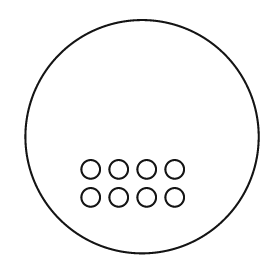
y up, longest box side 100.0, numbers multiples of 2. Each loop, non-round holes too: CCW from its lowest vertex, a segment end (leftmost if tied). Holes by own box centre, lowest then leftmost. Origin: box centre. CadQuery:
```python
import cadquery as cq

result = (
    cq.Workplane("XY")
    .moveTo(0.0, 0.0)
    .circle(50.0)
    .moveTo(-22.0, -26.0)
    .circle(4.0)
    .moveTo(-10.0, -26.0)
    .circle(4.0)
    .moveTo(2.0, -26.0)
    .circle(4.0)
    .moveTo(14.0, -26.0)
    .circle(4.0)
    .moveTo(-22.0, -14.0)
    .circle(4.0)
    .moveTo(-10.0, -14.0)
    .circle(4.0)
    .moveTo(2.0, -14.0)
    .circle(4.0)
    .moveTo(14.0, -14.0)
    .circle(4.0)
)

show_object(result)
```